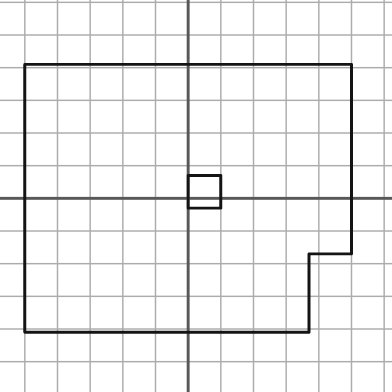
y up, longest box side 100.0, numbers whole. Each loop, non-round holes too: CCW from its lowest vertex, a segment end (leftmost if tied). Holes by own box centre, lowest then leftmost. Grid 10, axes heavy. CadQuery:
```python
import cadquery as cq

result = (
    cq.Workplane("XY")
    .moveTo(-50.0, -41.0)
    .lineTo(37.0, -41.0)
    .lineTo(37.0, -17.0)
    .lineTo(50.0, -17.0)
    .lineTo(50.0, 41.0)
    .lineTo(-50.0, 41.0)
    .close()
    .moveTo(0.0, -3.0)
    .lineTo(10.0, -3.0)
    .lineTo(10.0, 7.0)
    .lineTo(0.0, 7.0)
    .close()
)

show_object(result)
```